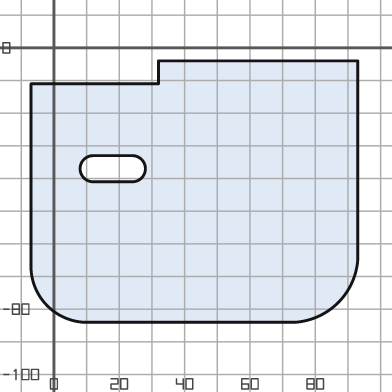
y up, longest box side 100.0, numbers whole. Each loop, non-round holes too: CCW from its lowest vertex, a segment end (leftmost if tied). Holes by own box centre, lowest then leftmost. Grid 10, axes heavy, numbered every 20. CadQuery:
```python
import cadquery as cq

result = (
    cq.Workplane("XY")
    .moveTo(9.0, -84.0)
    .lineTo(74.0, -84.0)
    .threePointArc((87.0, -78.0), (93.0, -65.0))
    .lineTo(93.0, -4.0)
    .lineTo(32.0, -4.0)
    .lineTo(32.0, -11.0)
    .lineTo(-7.0, -11.0)
    .lineTo(-7.0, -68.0)
    .threePointArc((-2.0, -79.0), (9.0, -84.0))
    .close()
    .moveTo(12.0, -41.0)
    .lineTo(24.0, -41.0)
    .threePointArc((28.0, -37.0), (24.0, -33.0))
    .lineTo(12.0, -33.0)
    .threePointArc((8.0, -37.0), (12.0, -41.0))
    .close()
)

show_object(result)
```